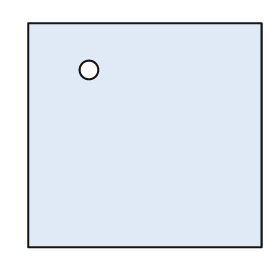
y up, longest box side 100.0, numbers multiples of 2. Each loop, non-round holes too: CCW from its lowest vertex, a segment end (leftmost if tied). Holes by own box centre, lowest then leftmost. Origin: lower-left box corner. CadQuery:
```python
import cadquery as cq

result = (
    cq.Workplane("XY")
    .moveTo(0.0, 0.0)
    .lineTo(100.0, 0.0)
    .lineTo(100.0, 96.0)
    .lineTo(0.0, 96.0)
    .close()
    .moveTo(26.0, 76.0)
    .circle(4.0)
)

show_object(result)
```